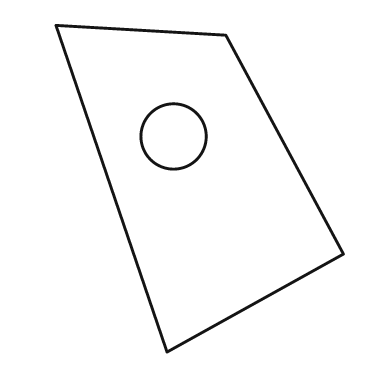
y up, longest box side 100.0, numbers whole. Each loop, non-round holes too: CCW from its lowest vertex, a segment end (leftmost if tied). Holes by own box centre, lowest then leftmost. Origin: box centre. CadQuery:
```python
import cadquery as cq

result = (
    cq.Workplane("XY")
    .moveTo(-10.0, -50.0)
    .lineTo(44.0, -20.0)
    .lineTo(8.0, 47.0)
    .lineTo(-44.0, 50.0)
    .close()
    .moveTo(-8.0, 16.0)
    .circle(10.0)
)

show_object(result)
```